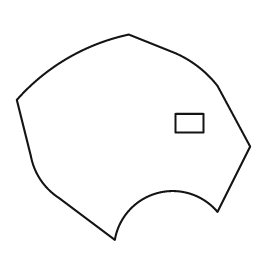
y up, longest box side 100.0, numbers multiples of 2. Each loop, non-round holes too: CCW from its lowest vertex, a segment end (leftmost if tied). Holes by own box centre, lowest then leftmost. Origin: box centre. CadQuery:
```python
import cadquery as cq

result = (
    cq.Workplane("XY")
    .moveTo(-8.0, -44.0)
    .threePointArc((10.0, -24.0), (36.0, -32.0))
    .lineTo(50.0, -4.0)
    .lineTo(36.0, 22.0)
    .threePointArc((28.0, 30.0), (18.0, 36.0))
    .lineTo(-2.0, 44.0)
    .threePointArc((-28.0, 34.0), (-50.0, 16.0))
    .lineTo(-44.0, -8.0)
    .threePointArc((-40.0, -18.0), (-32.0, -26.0))
    .close()
    .moveTo(18.0, 2.0)
    .lineTo(30.0, 2.0)
    .lineTo(30.0, 10.0)
    .lineTo(18.0, 10.0)
    .close()
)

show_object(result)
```